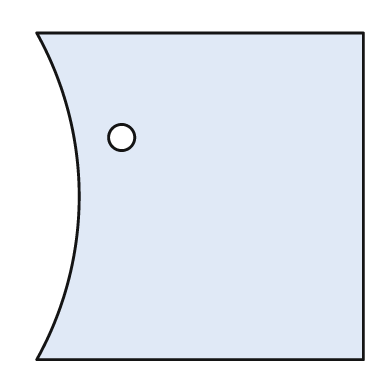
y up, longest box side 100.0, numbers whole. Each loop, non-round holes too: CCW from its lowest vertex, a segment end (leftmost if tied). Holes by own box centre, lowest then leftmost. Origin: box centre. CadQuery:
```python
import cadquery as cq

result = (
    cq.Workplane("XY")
    .moveTo(-50.0, -50.0)
    .lineTo(50.0, -50.0)
    .lineTo(50.0, 50.0)
    .lineTo(-50.0, 50.0)
    .threePointArc((-37.0, 0.0), (-50.0, -50.0))
    .close()
    .moveTo(-24.0, 18.0)
    .circle(4.0)
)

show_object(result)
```